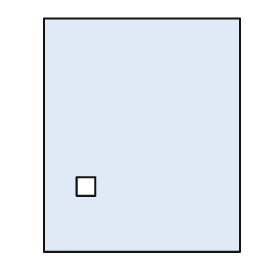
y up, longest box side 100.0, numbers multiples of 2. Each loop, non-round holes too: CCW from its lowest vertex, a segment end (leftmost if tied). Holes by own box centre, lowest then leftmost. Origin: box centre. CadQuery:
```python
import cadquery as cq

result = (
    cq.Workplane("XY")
    .moveTo(-42.0, -50.0)
    .lineTo(42.0, -50.0)
    .lineTo(42.0, 50.0)
    .lineTo(-42.0, 50.0)
    .close()
    .moveTo(-28.0, -26.0)
    .lineTo(-20.0, -26.0)
    .lineTo(-20.0, -18.0)
    .lineTo(-28.0, -18.0)
    .close()
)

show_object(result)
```